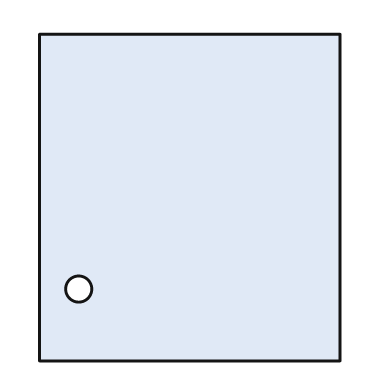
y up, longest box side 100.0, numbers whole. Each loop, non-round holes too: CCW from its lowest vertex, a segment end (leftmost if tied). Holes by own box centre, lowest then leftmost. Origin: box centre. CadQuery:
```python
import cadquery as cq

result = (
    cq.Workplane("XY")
    .moveTo(-46.0, -50.0)
    .lineTo(46.0, -50.0)
    .lineTo(46.0, 50.0)
    .lineTo(-46.0, 50.0)
    .close()
    .moveTo(-34.0, -28.0)
    .circle(4.0)
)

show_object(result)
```